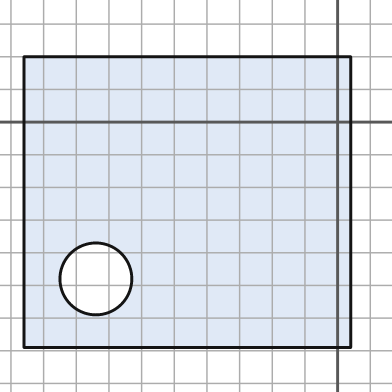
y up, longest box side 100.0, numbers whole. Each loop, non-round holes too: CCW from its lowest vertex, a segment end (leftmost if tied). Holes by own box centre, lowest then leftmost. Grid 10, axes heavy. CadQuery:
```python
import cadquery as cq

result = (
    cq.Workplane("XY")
    .moveTo(-96.0, -69.0)
    .lineTo(4.0, -69.0)
    .lineTo(4.0, 20.0)
    .lineTo(-96.0, 20.0)
    .close()
    .moveTo(-74.0, -48.0)
    .circle(11.0)
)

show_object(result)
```